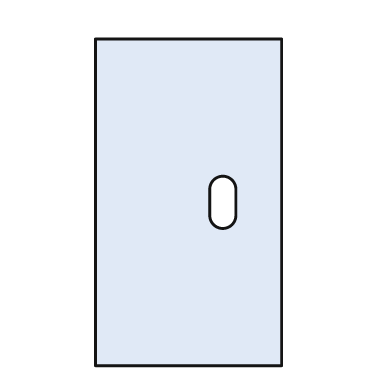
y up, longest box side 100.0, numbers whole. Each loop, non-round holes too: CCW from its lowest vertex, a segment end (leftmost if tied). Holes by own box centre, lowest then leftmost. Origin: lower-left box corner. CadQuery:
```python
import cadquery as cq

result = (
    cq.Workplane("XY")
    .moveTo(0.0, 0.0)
    .lineTo(57.0, 0.0)
    .lineTo(57.0, 100.0)
    .lineTo(0.0, 100.0)
    .close()
    .moveTo(35.0, 46.0)
    .threePointArc((39.0, 42.0), (43.0, 46.0))
    .lineTo(43.0, 54.0)
    .threePointArc((39.0, 58.0), (35.0, 54.0))
    .close()
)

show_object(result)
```